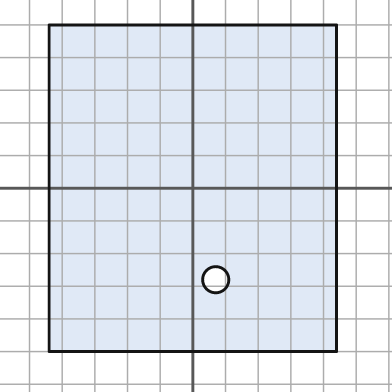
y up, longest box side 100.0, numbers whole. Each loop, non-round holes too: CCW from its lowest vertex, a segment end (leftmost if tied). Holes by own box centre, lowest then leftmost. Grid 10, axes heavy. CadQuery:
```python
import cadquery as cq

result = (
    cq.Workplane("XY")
    .moveTo(-44.0, -50.0)
    .lineTo(44.0, -50.0)
    .lineTo(44.0, 50.0)
    .lineTo(-44.0, 50.0)
    .close()
    .moveTo(7.0, -28.0)
    .circle(4.0)
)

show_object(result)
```